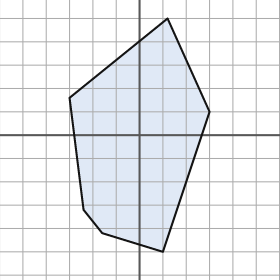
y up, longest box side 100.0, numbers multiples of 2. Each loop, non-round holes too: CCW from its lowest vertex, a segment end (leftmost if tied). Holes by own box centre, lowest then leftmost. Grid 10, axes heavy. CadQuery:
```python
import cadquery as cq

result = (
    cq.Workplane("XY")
    .moveTo(10.0, -50.0)
    .lineTo(30.0, 10.0)
    .lineTo(12.0, 50.0)
    .lineTo(-30.0, 16.0)
    .lineTo(-24.0, -32.0)
    .lineTo(-16.0, -42.0)
    .close()
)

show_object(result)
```